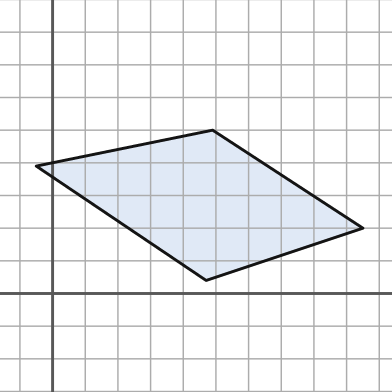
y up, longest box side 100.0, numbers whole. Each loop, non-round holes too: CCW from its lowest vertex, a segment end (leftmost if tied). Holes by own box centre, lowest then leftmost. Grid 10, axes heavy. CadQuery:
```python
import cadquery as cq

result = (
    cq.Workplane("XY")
    .moveTo(47.0, 4.0)
    .lineTo(95.0, 20.0)
    .lineTo(49.0, 50.0)
    .lineTo(-5.0, 39.0)
    .close()
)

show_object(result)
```